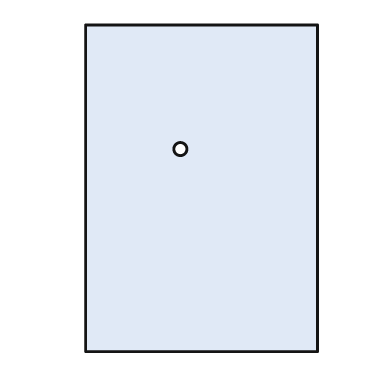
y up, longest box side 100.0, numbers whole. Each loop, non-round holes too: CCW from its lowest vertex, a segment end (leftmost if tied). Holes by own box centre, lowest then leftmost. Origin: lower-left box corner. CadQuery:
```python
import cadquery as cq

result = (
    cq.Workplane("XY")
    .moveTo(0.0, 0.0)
    .lineTo(71.0, 0.0)
    .lineTo(71.0, 100.0)
    .lineTo(0.0, 100.0)
    .close()
    .moveTo(29.0, 62.0)
    .circle(2.0)
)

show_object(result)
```